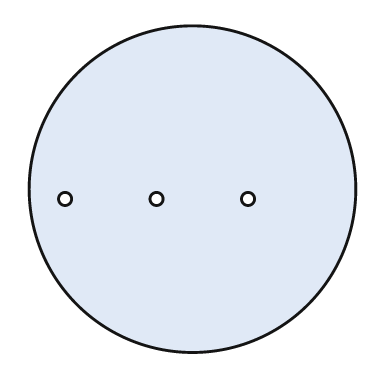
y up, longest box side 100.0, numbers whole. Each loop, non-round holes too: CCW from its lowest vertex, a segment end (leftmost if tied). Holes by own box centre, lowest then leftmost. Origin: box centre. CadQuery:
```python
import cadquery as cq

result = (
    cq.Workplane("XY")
    .moveTo(0.0, 0.0)
    .circle(50.0)
    .moveTo(-39.0, -3.0)
    .circle(2.0)
    .moveTo(-11.0, -3.0)
    .circle(2.0)
    .moveTo(17.0, -3.0)
    .circle(2.0)
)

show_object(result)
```